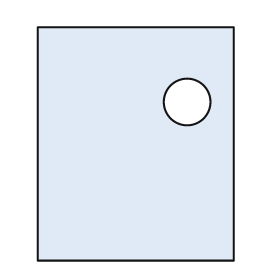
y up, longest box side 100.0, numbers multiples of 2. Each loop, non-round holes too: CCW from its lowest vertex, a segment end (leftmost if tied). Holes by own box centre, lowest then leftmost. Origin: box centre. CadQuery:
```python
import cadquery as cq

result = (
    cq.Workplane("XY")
    .moveTo(-42.0, -50.0)
    .lineTo(42.0, -50.0)
    .lineTo(42.0, 50.0)
    .lineTo(-42.0, 50.0)
    .close()
    .moveTo(22.0, 18.0)
    .circle(10.0)
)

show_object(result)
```